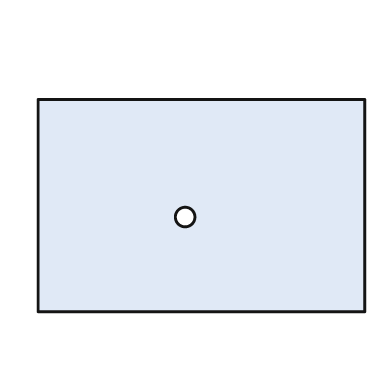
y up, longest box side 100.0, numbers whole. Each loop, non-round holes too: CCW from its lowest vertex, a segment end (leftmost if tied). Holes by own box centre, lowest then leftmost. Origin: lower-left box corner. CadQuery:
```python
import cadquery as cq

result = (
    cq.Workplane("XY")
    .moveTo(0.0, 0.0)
    .lineTo(100.0, 0.0)
    .lineTo(100.0, 65.0)
    .lineTo(0.0, 65.0)
    .close()
    .moveTo(45.0, 29.0)
    .circle(3.0)
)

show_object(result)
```